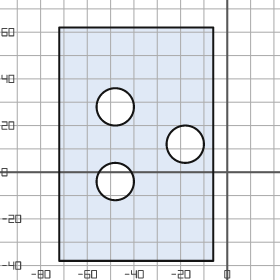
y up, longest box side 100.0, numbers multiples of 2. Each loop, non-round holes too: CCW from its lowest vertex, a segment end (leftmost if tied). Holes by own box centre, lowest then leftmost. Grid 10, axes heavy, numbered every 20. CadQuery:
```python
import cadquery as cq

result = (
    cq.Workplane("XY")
    .moveTo(-72.0, -38.0)
    .lineTo(-6.0, -38.0)
    .lineTo(-6.0, 62.0)
    .lineTo(-72.0, 62.0)
    .close()
    .moveTo(-48.0, -4.0)
    .circle(8.0)
    .moveTo(-18.0, 12.0)
    .circle(8.0)
    .moveTo(-48.0, 28.0)
    .circle(8.0)
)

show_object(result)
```